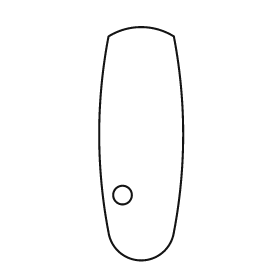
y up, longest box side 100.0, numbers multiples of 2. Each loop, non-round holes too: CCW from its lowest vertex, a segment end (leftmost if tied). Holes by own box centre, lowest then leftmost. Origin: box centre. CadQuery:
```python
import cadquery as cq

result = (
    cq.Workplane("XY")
    .moveTo(-14.0, -38.0)
    .threePointArc((0.0, -50.0), (14.0, -38.0))
    .threePointArc((18.0, 4.0), (14.0, 46.0))
    .threePointArc((0.0, 50.0), (-14.0, 46.0))
    .threePointArc((-18.0, 4.0), (-14.0, -38.0))
    .close()
    .moveTo(-8.0, -22.0)
    .circle(4.0)
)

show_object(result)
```